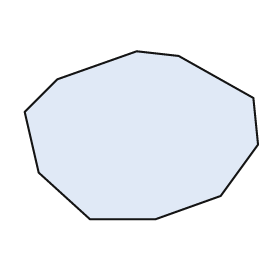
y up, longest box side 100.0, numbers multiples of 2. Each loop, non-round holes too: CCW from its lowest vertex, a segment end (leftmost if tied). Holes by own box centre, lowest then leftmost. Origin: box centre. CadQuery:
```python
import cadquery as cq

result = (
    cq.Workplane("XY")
    .moveTo(-22.0, -36.0)
    .lineTo(6.0, -36.0)
    .lineTo(34.0, -26.0)
    .lineTo(50.0, -4.0)
    .lineTo(48.0, 16.0)
    .lineTo(16.0, 34.0)
    .lineTo(-2.0, 36.0)
    .lineTo(-36.0, 24.0)
    .lineTo(-50.0, 10.0)
    .lineTo(-44.0, -16.0)
    .close()
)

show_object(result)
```